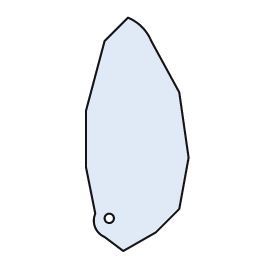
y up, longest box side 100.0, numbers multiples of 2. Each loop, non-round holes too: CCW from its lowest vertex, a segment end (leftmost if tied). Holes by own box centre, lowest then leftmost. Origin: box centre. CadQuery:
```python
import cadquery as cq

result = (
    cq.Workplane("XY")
    .moveTo(-6.0, -50.0)
    .lineTo(8.0, -42.0)
    .lineTo(18.0, -32.0)
    .lineTo(22.0, -10.0)
    .lineTo(18.0, 18.0)
    .lineTo(6.0, 40.0)
    .threePointArc((2.0, 46.0), (-4.0, 50.0))
    .lineTo(-14.0, 40.0)
    .lineTo(-22.0, 10.0)
    .lineTo(-22.0, -14.0)
    .lineTo(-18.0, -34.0)
    .threePointArc((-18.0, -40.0), (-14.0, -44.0))
    .close()
    .moveTo(-12.0, -36.0)
    .circle(2.0)
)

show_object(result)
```